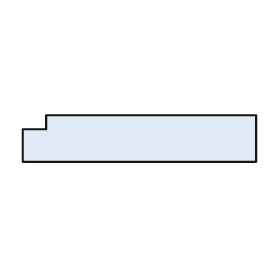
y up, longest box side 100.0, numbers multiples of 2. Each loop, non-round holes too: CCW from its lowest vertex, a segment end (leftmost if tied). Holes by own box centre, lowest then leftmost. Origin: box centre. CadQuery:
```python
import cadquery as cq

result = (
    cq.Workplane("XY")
    .moveTo(-50.0, -10.0)
    .lineTo(50.0, -10.0)
    .lineTo(50.0, 10.0)
    .lineTo(-40.0, 10.0)
    .lineTo(-40.0, 4.0)
    .lineTo(-50.0, 4.0)
    .close()
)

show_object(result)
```